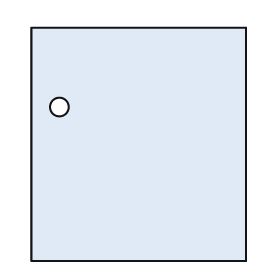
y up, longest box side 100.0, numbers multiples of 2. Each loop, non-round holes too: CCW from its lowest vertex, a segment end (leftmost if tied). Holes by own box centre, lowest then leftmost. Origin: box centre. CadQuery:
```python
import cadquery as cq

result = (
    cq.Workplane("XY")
    .moveTo(-46.0, -50.0)
    .lineTo(46.0, -50.0)
    .lineTo(46.0, 50.0)
    .lineTo(-46.0, 50.0)
    .close()
    .moveTo(-34.0, 16.0)
    .circle(4.0)
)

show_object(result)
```